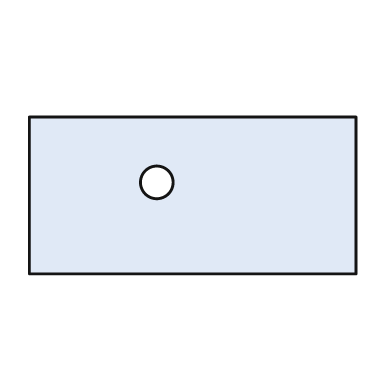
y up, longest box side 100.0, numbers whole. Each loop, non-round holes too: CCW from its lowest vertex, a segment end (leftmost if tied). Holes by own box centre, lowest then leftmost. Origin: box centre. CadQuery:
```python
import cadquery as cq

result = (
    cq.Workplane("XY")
    .moveTo(-50.0, -24.0)
    .lineTo(50.0, -24.0)
    .lineTo(50.0, 24.0)
    .lineTo(-50.0, 24.0)
    .close()
    .moveTo(-11.0, 4.0)
    .circle(5.0)
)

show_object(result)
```